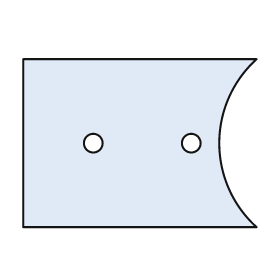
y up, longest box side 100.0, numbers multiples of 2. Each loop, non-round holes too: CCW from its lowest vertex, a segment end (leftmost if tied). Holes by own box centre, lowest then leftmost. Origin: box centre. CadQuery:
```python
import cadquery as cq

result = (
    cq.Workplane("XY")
    .moveTo(-50.0, -36.0)
    .lineTo(50.0, -36.0)
    .threePointArc((34.0, 0.0), (50.0, 36.0))
    .lineTo(-50.0, 36.0)
    .close()
    .moveTo(-20.0, 0.0)
    .circle(4.0)
    .moveTo(22.0, 0.0)
    .circle(4.0)
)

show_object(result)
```